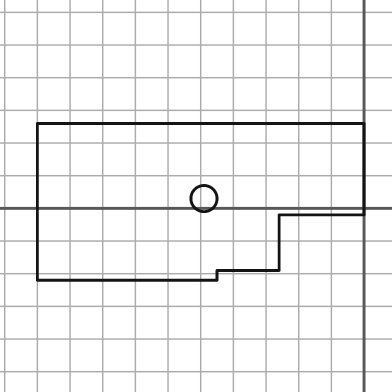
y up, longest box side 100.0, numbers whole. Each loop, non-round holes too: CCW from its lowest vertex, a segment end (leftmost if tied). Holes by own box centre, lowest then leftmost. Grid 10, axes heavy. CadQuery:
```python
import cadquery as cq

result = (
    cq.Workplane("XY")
    .moveTo(-100.0, -22.0)
    .lineTo(-45.0, -22.0)
    .lineTo(-45.0, -19.0)
    .lineTo(-26.0, -19.0)
    .lineTo(-26.0, -2.0)
    .lineTo(0.0, -2.0)
    .lineTo(0.0, 26.0)
    .lineTo(-100.0, 26.0)
    .close()
    .moveTo(-49.0, 3.0)
    .circle(4.0)
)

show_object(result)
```